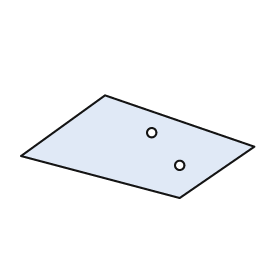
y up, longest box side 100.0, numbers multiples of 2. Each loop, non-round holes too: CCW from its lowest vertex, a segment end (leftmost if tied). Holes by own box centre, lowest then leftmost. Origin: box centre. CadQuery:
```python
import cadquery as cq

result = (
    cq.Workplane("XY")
    .moveTo(18.0, -22.0)
    .lineTo(50.0, 0.0)
    .lineTo(-14.0, 22.0)
    .lineTo(-50.0, -4.0)
    .close()
    .moveTo(18.0, -8.0)
    .circle(2.0)
    .moveTo(6.0, 6.0)
    .circle(2.0)
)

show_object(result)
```